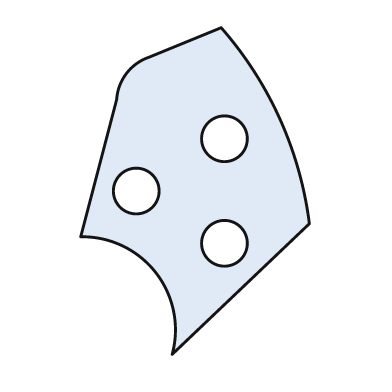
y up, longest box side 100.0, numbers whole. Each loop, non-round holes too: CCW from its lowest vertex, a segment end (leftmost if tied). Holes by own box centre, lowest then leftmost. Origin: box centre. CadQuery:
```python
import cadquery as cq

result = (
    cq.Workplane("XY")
    .moveTo(-7.0, -50.0)
    .lineTo(35.0, -10.0)
    .threePointArc((26.0, 22.0), (8.0, 50.0))
    .lineTo(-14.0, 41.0)
    .threePointArc((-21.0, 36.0), (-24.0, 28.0))
    .lineTo(-35.0, -14.0)
    .threePointArc((-12.0, -25.0), (-7.0, -50.0))
    .close()
    .moveTo(9.0, -16.0)
    .circle(7.0)
    .moveTo(-18.0, 0.0)
    .circle(7.0)
    .moveTo(9.0, 16.0)
    .circle(7.0)
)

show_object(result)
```